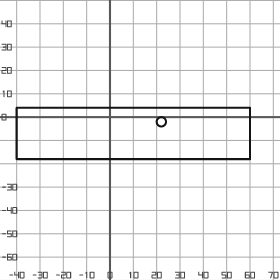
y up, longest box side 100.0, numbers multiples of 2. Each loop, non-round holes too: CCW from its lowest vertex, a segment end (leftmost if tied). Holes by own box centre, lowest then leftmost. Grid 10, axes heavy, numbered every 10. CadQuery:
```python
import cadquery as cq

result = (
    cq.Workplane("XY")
    .moveTo(-40.0, -18.0)
    .lineTo(60.0, -18.0)
    .lineTo(60.0, 4.0)
    .lineTo(-40.0, 4.0)
    .close()
    .moveTo(22.0, -2.0)
    .circle(2.0)
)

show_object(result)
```